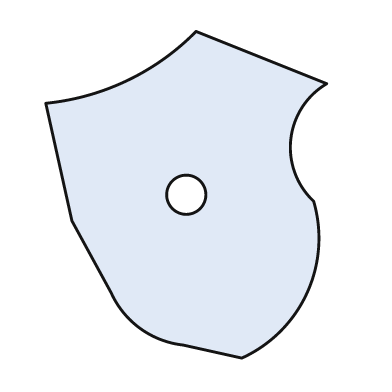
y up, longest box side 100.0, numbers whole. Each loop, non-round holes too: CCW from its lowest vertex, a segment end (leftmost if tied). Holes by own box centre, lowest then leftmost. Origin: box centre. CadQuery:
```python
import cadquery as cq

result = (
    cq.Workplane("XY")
    .moveTo(17.0, -50.0)
    .threePointArc((37.0, -30.0), (39.0, -2.0))
    .threePointArc((32.0, 17.0), (43.0, 34.0))
    .lineTo(3.0, 50.0)
    .threePointArc((-18.0, 35.0), (-43.0, 28.0))
    .lineTo(-35.0, -8.0)
    .lineTo(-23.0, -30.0)
    .threePointArc((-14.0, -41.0), (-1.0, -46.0))
    .close()
    .moveTo(0.0, 0.0)
    .circle(6.0)
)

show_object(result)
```